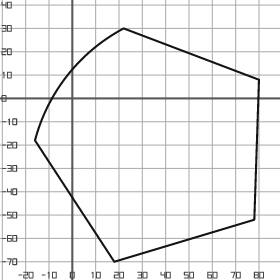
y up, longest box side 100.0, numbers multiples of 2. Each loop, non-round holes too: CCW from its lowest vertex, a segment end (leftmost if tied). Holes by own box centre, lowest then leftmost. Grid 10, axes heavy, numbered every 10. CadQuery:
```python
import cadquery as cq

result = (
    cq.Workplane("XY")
    .moveTo(18.0, -70.0)
    .lineTo(78.0, -52.0)
    .lineTo(80.0, 8.0)
    .lineTo(22.0, 30.0)
    .threePointArc((-2.0, 10.0), (-16.0, -18.0))
    .close()
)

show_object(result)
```